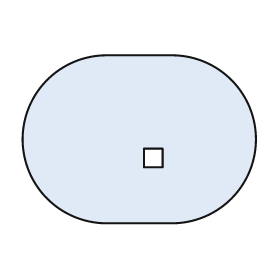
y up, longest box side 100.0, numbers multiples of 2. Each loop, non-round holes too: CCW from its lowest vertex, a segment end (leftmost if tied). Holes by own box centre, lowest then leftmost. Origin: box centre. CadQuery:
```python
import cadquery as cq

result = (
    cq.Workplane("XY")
    .moveTo(-14.0, -36.0)
    .lineTo(14.0, -36.0)
    .threePointArc((50.0, 0.0), (14.0, 36.0))
    .lineTo(-14.0, 36.0)
    .threePointArc((-50.0, 0.0), (-14.0, -36.0))
    .close()
    .moveTo(2.0, -12.0)
    .lineTo(10.0, -12.0)
    .lineTo(10.0, -4.0)
    .lineTo(2.0, -4.0)
    .close()
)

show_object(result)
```